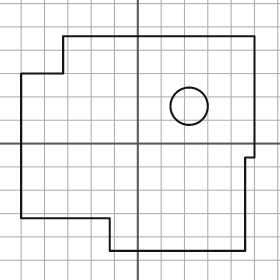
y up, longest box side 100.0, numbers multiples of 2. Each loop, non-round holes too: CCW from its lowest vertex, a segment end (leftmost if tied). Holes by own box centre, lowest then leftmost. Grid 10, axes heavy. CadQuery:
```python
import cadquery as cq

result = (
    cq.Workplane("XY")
    .moveTo(-12.0, -46.0)
    .lineTo(46.0, -46.0)
    .lineTo(46.0, -6.0)
    .lineTo(50.0, -6.0)
    .lineTo(50.0, 46.0)
    .lineTo(-32.0, 46.0)
    .lineTo(-32.0, 30.0)
    .lineTo(-50.0, 30.0)
    .lineTo(-50.0, -32.0)
    .lineTo(-12.0, -32.0)
    .close()
    .moveTo(22.0, 16.0)
    .circle(8.0)
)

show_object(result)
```